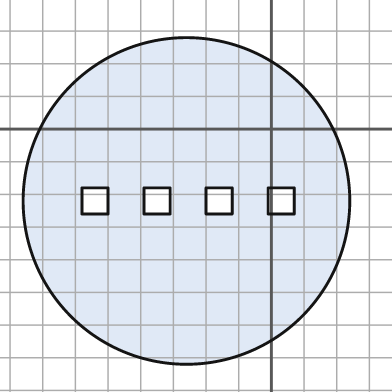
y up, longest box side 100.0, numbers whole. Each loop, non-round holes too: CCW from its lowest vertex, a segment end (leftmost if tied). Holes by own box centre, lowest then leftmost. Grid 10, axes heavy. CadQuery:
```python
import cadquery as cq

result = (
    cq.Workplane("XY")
    .moveTo(-26.0, -22.0)
    .circle(50.0)
    .moveTo(-58.0, -26.0)
    .lineTo(-50.0, -26.0)
    .lineTo(-50.0, -18.0)
    .lineTo(-58.0, -18.0)
    .close()
    .moveTo(-39.0, -26.0)
    .lineTo(-31.0, -26.0)
    .lineTo(-31.0, -18.0)
    .lineTo(-39.0, -18.0)
    .close()
    .moveTo(-20.0, -26.0)
    .lineTo(-12.0, -26.0)
    .lineTo(-12.0, -18.0)
    .lineTo(-20.0, -18.0)
    .close()
    .moveTo(-1.0, -26.0)
    .lineTo(7.0, -26.0)
    .lineTo(7.0, -18.0)
    .lineTo(-1.0, -18.0)
    .close()
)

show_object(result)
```